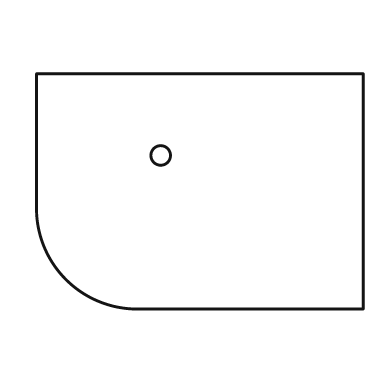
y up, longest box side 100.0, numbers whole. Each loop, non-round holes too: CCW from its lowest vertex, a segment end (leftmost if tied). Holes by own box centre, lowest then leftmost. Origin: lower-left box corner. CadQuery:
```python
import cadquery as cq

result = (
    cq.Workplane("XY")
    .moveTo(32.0, 0.0)
    .lineTo(100.0, 0.0)
    .lineTo(100.0, 72.0)
    .lineTo(0.0, 72.0)
    .lineTo(0.0, 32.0)
    .threePointArc((9.0, 9.0), (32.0, 0.0))
    .close()
    .moveTo(38.0, 47.0)
    .circle(3.0)
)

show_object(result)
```